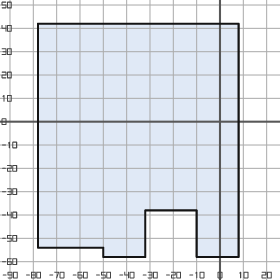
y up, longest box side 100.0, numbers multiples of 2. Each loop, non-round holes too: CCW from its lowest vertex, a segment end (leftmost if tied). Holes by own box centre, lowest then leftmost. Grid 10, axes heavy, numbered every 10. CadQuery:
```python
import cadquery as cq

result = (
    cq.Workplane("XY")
    .moveTo(-50.0, -58.0)
    .lineTo(-32.0, -58.0)
    .lineTo(-32.0, -38.0)
    .lineTo(-10.0, -38.0)
    .lineTo(-10.0, -58.0)
    .lineTo(8.0, -58.0)
    .lineTo(8.0, 42.0)
    .lineTo(-78.0, 42.0)
    .lineTo(-78.0, -54.0)
    .lineTo(-50.0, -54.0)
    .close()
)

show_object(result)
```